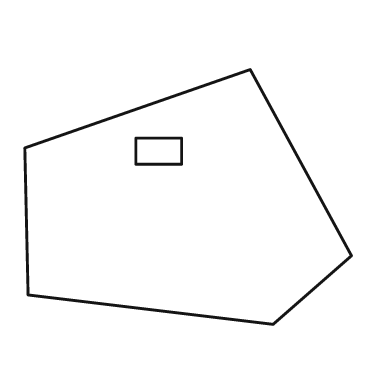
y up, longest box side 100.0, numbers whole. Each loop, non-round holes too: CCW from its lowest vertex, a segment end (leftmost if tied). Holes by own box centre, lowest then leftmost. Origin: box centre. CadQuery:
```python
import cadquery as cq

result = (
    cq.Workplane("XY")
    .moveTo(26.0, -39.0)
    .lineTo(50.0, -18.0)
    .lineTo(19.0, 39.0)
    .lineTo(-50.0, 15.0)
    .lineTo(-49.0, -30.0)
    .close()
    .moveTo(-16.0, 10.0)
    .lineTo(-2.0, 10.0)
    .lineTo(-2.0, 18.0)
    .lineTo(-16.0, 18.0)
    .close()
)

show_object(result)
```